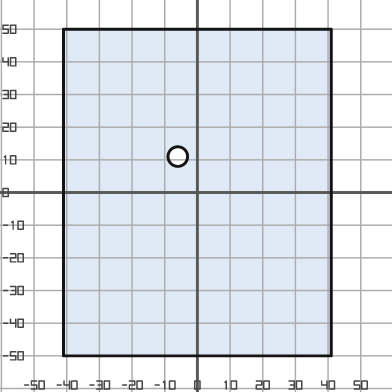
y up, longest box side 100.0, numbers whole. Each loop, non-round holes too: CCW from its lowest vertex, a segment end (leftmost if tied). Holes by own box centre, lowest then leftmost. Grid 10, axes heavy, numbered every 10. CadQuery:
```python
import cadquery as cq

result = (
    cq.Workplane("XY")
    .moveTo(-41.0, -50.0)
    .lineTo(41.0, -50.0)
    .lineTo(41.0, 50.0)
    .lineTo(-41.0, 50.0)
    .close()
    .moveTo(-6.0, 11.0)
    .circle(3.0)
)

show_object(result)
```